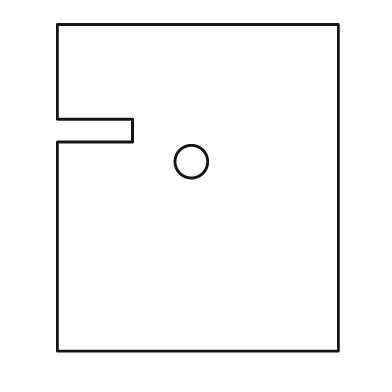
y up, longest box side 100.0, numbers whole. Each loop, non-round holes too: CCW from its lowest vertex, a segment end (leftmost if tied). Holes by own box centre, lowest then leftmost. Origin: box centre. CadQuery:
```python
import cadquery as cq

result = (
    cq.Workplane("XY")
    .moveTo(-43.0, -50.0)
    .lineTo(43.0, -50.0)
    .lineTo(43.0, 50.0)
    .lineTo(-43.0, 50.0)
    .lineTo(-43.0, 21.0)
    .lineTo(-20.0, 21.0)
    .lineTo(-20.0, 14.0)
    .lineTo(-43.0, 14.0)
    .close()
    .moveTo(-2.0, 8.0)
    .circle(5.0)
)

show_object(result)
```